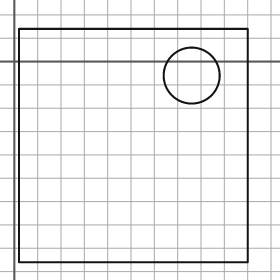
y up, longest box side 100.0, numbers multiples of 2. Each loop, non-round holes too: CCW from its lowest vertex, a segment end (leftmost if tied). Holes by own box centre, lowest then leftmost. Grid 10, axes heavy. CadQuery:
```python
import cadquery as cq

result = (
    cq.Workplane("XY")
    .moveTo(2.0, -86.0)
    .lineTo(100.0, -86.0)
    .lineTo(100.0, 14.0)
    .lineTo(2.0, 14.0)
    .close()
    .moveTo(76.0, -6.0)
    .circle(12.0)
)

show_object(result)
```